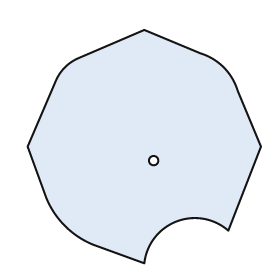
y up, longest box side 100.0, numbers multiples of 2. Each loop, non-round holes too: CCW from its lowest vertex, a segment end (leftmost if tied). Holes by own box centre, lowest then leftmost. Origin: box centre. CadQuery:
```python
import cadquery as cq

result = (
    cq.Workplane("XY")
    .moveTo(0.0, -50.0)
    .threePointArc((14.0, -32.0), (36.0, -36.0))
    .lineTo(50.0, 0.0)
    .lineTo(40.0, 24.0)
    .threePointArc((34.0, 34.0), (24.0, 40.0))
    .lineTo(0.0, 50.0)
    .lineTo(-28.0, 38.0)
    .threePointArc((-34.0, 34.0), (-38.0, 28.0))
    .lineTo(-50.0, 0.0)
    .lineTo(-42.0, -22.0)
    .threePointArc((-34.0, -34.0), (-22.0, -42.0))
    .close()
    .moveTo(4.0, -6.0)
    .circle(2.0)
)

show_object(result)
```